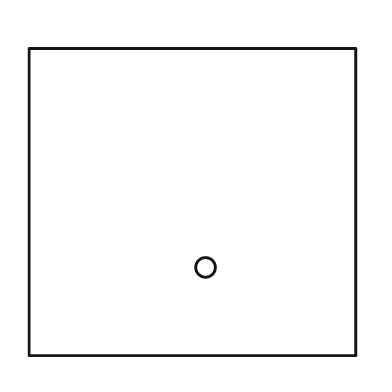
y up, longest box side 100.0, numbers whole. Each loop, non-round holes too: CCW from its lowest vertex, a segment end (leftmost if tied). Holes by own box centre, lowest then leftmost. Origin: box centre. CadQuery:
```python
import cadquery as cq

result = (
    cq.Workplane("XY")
    .moveTo(-50.0, -47.0)
    .lineTo(50.0, -47.0)
    .lineTo(50.0, 47.0)
    .lineTo(-50.0, 47.0)
    .close()
    .moveTo(4.0, -20.0)
    .circle(3.0)
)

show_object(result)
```